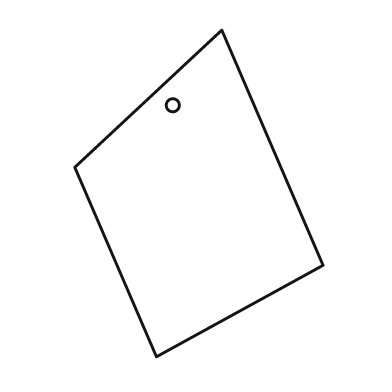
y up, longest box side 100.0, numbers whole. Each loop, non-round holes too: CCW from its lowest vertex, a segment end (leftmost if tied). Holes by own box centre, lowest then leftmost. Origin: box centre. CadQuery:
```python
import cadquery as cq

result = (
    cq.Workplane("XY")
    .moveTo(-13.0, -50.0)
    .lineTo(38.0, -22.0)
    .lineTo(7.0, 50.0)
    .lineTo(-38.0, 8.0)
    .close()
    .moveTo(-8.0, 27.0)
    .circle(2.0)
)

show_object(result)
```